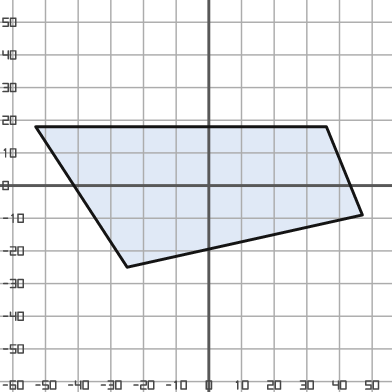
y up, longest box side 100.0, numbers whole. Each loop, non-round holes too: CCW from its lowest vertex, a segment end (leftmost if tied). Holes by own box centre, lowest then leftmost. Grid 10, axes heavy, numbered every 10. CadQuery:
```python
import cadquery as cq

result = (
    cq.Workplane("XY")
    .moveTo(-25.0, -25.0)
    .lineTo(47.0, -9.0)
    .lineTo(36.0, 18.0)
    .lineTo(-53.0, 18.0)
    .close()
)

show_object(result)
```